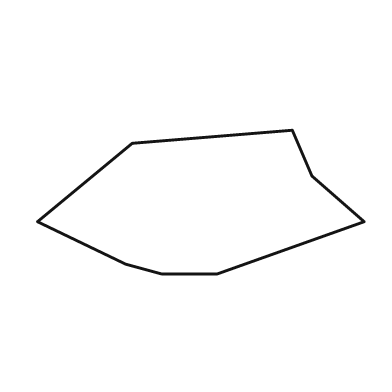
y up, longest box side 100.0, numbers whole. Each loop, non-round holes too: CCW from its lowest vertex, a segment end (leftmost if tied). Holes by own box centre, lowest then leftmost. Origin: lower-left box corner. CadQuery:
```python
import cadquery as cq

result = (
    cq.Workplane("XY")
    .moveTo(38.0, 0.0)
    .lineTo(55.0, 0.0)
    .lineTo(100.0, 16.0)
    .lineTo(84.0, 30.0)
    .lineTo(78.0, 44.0)
    .lineTo(29.0, 40.0)
    .lineTo(0.0, 16.0)
    .lineTo(27.0, 3.0)
    .close()
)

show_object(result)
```